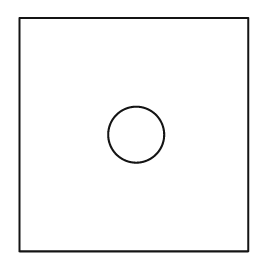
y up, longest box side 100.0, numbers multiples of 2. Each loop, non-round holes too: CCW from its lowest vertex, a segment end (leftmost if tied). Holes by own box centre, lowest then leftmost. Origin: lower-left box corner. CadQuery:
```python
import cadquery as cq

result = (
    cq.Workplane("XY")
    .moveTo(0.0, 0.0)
    .lineTo(98.0, 0.0)
    .lineTo(98.0, 100.0)
    .lineTo(0.0, 100.0)
    .close()
    .moveTo(50.0, 50.0)
    .circle(12.0)
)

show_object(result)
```